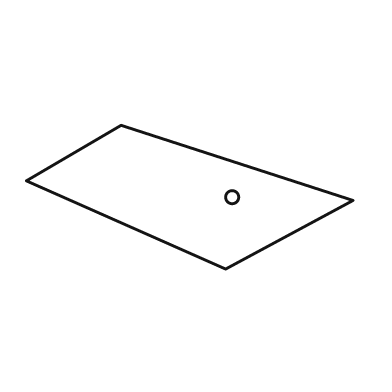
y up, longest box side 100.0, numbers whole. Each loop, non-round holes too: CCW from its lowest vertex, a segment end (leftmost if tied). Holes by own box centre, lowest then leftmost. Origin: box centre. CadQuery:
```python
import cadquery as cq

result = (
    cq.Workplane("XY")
    .moveTo(11.0, -22.0)
    .lineTo(50.0, -1.0)
    .lineTo(-21.0, 22.0)
    .lineTo(-50.0, 5.0)
    .close()
    .moveTo(13.0, 0.0)
    .circle(2.0)
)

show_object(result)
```